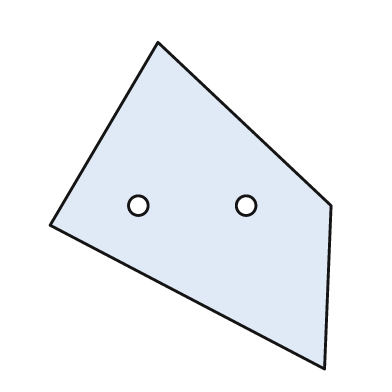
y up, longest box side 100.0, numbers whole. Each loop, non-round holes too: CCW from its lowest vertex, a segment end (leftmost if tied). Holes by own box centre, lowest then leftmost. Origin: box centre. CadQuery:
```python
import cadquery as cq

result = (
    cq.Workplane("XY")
    .moveTo(41.0, -50.0)
    .lineTo(43.0, 0.0)
    .lineTo(-10.0, 50.0)
    .lineTo(-43.0, -6.0)
    .close()
    .moveTo(-16.0, 0.0)
    .circle(3.0)
    .moveTo(17.0, 0.0)
    .circle(3.0)
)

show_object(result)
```